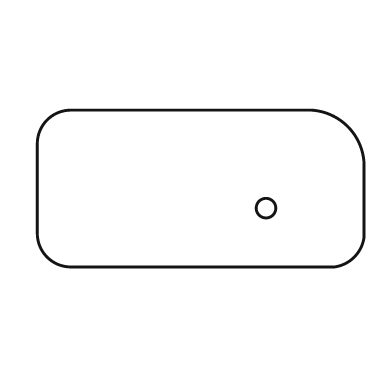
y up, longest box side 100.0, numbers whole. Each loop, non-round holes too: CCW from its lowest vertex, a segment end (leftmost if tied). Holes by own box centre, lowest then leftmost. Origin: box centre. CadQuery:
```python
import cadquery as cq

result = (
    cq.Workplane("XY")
    .moveTo(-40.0, -24.0)
    .lineTo(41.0, -24.0)
    .threePointArc((47.0, -21.0), (50.0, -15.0))
    .lineTo(50.0, 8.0)
    .threePointArc((45.0, 19.0), (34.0, 24.0))
    .lineTo(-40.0, 24.0)
    .threePointArc((-47.0, 21.0), (-50.0, 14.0))
    .lineTo(-50.0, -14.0)
    .threePointArc((-47.0, -21.0), (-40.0, -24.0))
    .close()
    .moveTo(20.0, -6.0)
    .circle(3.0)
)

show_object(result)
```